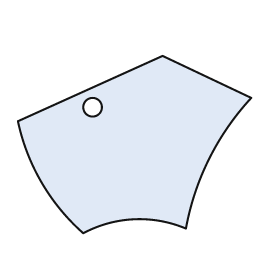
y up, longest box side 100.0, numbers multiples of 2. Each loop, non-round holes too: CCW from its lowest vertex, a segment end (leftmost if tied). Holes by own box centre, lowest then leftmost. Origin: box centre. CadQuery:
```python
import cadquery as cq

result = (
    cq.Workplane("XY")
    .moveTo(-22.0, -38.0)
    .threePointArc((0.0, -32.0), (22.0, -36.0))
    .threePointArc((32.0, -6.0), (50.0, 20.0))
    .lineTo(12.0, 38.0)
    .lineTo(-50.0, 10.0)
    .threePointArc((-40.0, -16.0), (-22.0, -38.0))
    .close()
    .moveTo(-18.0, 16.0)
    .circle(4.0)
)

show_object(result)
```